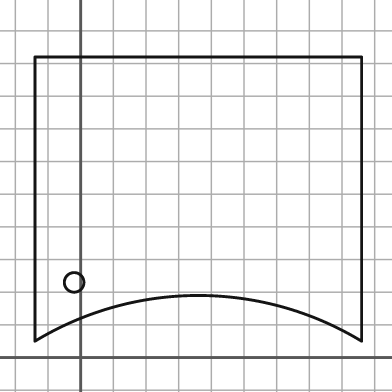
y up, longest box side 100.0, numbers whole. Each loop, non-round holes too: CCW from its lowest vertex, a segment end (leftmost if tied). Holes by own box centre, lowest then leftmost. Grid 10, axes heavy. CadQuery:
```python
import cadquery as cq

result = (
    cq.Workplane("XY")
    .moveTo(-14.0, 5.0)
    .threePointArc((36.0, 19.0), (86.0, 5.0))
    .lineTo(86.0, 92.0)
    .lineTo(-14.0, 92.0)
    .close()
    .moveTo(-2.0, 23.0)
    .circle(3.0)
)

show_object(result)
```